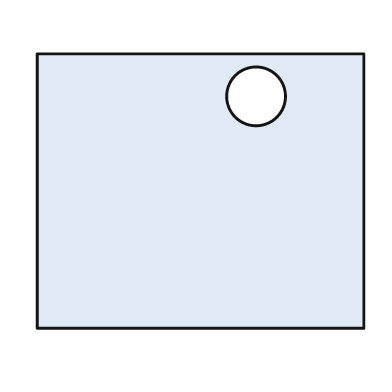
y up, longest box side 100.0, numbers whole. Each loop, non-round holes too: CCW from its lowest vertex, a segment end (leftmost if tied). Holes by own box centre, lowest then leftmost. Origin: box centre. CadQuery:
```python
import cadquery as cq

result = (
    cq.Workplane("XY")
    .moveTo(-50.0, -42.0)
    .lineTo(50.0, -42.0)
    .lineTo(50.0, 42.0)
    .lineTo(-50.0, 42.0)
    .close()
    .moveTo(17.0, 29.0)
    .circle(9.0)
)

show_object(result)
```